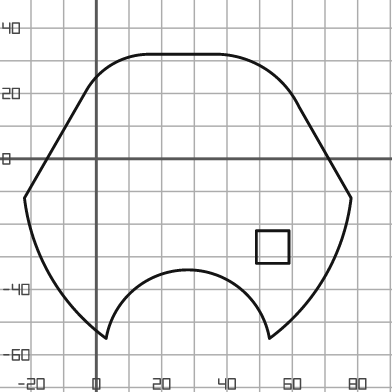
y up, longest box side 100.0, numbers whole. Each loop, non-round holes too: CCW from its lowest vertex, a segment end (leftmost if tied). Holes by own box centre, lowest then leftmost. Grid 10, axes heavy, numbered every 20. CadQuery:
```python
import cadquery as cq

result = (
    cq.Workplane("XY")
    .moveTo(3.0, -55.0)
    .threePointArc((28.0, -34.0), (53.0, -55.0))
    .threePointArc((70.0, -36.0), (78.0, -12.0))
    .lineTo(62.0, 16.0)
    .threePointArc((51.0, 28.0), (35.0, 32.0))
    .lineTo(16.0, 32.0)
    .threePointArc((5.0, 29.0), (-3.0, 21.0))
    .lineTo(-22.0, -12.0)
    .threePointArc((-14.0, -36.0), (3.0, -55.0))
    .close()
    .moveTo(49.0, -32.0)
    .lineTo(59.0, -32.0)
    .lineTo(59.0, -22.0)
    .lineTo(49.0, -22.0)
    .close()
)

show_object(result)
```